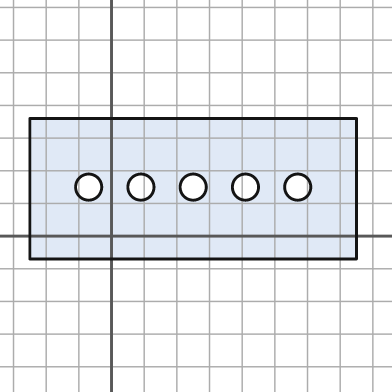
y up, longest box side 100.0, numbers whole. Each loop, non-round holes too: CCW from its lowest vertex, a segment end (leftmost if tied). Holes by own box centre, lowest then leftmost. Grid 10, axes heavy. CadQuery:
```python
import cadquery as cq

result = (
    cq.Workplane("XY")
    .moveTo(-25.0, -7.0)
    .lineTo(75.0, -7.0)
    .lineTo(75.0, 36.0)
    .lineTo(-25.0, 36.0)
    .close()
    .moveTo(-7.0, 15.0)
    .circle(4.0)
    .moveTo(9.0, 15.0)
    .circle(4.0)
    .moveTo(25.0, 15.0)
    .circle(4.0)
    .moveTo(41.0, 15.0)
    .circle(4.0)
    .moveTo(57.0, 15.0)
    .circle(4.0)
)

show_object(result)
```